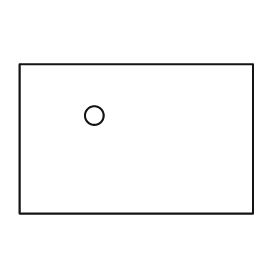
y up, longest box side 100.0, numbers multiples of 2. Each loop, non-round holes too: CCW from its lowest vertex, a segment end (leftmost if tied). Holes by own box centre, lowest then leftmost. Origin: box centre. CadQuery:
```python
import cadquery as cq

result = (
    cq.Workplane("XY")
    .moveTo(-50.0, -32.0)
    .lineTo(50.0, -32.0)
    .lineTo(50.0, 32.0)
    .lineTo(-50.0, 32.0)
    .close()
    .moveTo(-18.0, 10.0)
    .circle(4.0)
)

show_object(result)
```